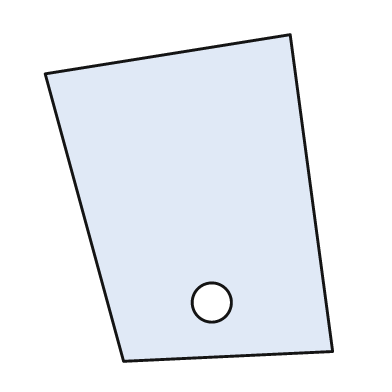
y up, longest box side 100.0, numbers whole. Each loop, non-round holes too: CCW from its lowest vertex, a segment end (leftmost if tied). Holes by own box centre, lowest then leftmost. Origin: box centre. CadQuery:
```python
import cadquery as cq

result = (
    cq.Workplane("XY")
    .moveTo(-20.0, -50.0)
    .lineTo(44.0, -47.0)
    .lineTo(31.0, 50.0)
    .lineTo(-44.0, 38.0)
    .close()
    .moveTo(7.0, -32.0)
    .circle(6.0)
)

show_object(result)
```